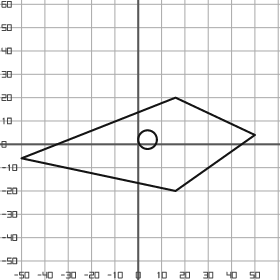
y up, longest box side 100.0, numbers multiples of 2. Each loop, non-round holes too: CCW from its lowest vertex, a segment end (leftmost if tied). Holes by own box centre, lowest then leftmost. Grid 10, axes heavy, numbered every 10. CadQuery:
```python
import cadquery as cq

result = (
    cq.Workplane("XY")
    .moveTo(16.0, -20.0)
    .lineTo(50.0, 4.0)
    .lineTo(16.0, 20.0)
    .lineTo(-50.0, -6.0)
    .close()
    .moveTo(4.0, 2.0)
    .circle(4.0)
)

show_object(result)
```